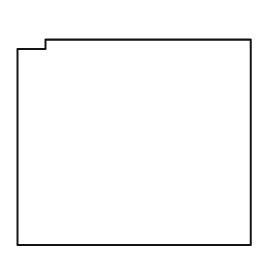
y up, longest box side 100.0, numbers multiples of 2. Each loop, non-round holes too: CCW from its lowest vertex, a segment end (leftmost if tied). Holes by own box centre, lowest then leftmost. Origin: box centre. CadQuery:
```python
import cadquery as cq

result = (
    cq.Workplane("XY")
    .moveTo(-50.0, -44.0)
    .lineTo(50.0, -44.0)
    .lineTo(50.0, 44.0)
    .lineTo(-38.0, 44.0)
    .lineTo(-38.0, 40.0)
    .lineTo(-50.0, 40.0)
    .close()
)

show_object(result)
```